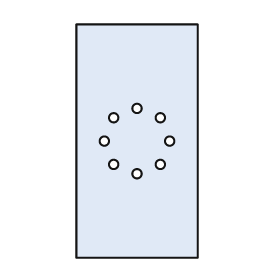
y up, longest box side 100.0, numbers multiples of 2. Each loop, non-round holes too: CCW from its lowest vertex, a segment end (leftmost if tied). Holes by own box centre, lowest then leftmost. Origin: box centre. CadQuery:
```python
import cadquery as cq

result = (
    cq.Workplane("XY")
    .moveTo(-26.0, -50.0)
    .lineTo(26.0, -50.0)
    .lineTo(26.0, 50.0)
    .lineTo(-26.0, 50.0)
    .close()
    .moveTo(0.0, -14.0)
    .circle(2.0)
    .moveTo(-10.0, -10.0)
    .circle(2.0)
    .moveTo(10.0, -10.0)
    .circle(2.0)
    .moveTo(-14.0, 0.0)
    .circle(2.0)
    .moveTo(14.0, 0.0)
    .circle(2.0)
    .moveTo(-10.0, 10.0)
    .circle(2.0)
    .moveTo(10.0, 10.0)
    .circle(2.0)
    .moveTo(0.0, 14.0)
    .circle(2.0)
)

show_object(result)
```